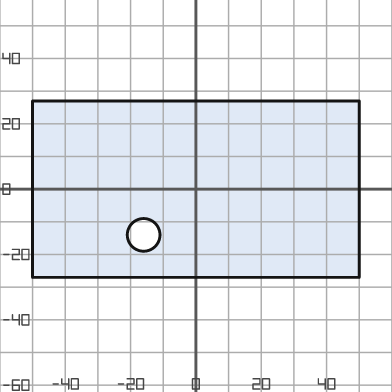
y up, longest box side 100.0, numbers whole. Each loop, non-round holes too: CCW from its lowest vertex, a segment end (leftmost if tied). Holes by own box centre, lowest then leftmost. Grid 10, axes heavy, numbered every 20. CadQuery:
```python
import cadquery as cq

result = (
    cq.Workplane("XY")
    .moveTo(-50.0, -27.0)
    .lineTo(50.0, -27.0)
    .lineTo(50.0, 27.0)
    .lineTo(-50.0, 27.0)
    .close()
    .moveTo(-16.0, -14.0)
    .circle(5.0)
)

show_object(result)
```